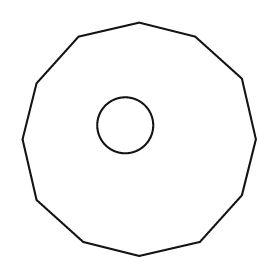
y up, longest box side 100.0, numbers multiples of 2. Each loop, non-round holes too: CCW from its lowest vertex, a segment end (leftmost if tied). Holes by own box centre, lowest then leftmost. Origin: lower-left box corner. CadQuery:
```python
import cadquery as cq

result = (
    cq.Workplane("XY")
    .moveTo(50.0, 0.0)
    .lineTo(76.0, 6.0)
    .lineTo(94.0, 26.0)
    .lineTo(100.0, 50.0)
    .lineTo(94.0, 76.0)
    .lineTo(74.0, 94.0)
    .lineTo(50.0, 100.0)
    .lineTo(24.0, 94.0)
    .lineTo(6.0, 74.0)
    .lineTo(0.0, 50.0)
    .lineTo(6.0, 24.0)
    .lineTo(26.0, 6.0)
    .close()
    .moveTo(44.0, 56.0)
    .circle(12.0)
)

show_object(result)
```